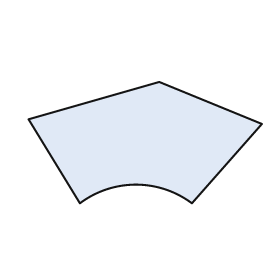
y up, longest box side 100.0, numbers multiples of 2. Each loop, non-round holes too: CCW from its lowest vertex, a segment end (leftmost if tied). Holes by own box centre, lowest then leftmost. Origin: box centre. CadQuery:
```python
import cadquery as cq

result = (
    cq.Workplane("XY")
    .moveTo(-28.0, -26.0)
    .threePointArc((-4.0, -18.0), (20.0, -26.0))
    .lineTo(50.0, 8.0)
    .lineTo(6.0, 26.0)
    .lineTo(-50.0, 10.0)
    .close()
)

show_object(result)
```